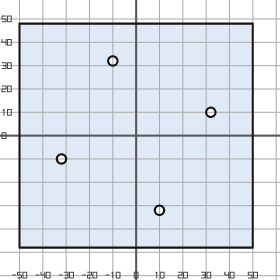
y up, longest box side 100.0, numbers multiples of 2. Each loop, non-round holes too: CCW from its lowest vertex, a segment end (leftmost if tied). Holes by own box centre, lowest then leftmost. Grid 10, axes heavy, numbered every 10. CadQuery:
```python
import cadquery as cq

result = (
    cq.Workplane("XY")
    .moveTo(-50.0, -48.0)
    .lineTo(50.0, -48.0)
    .lineTo(50.0, 48.0)
    .lineTo(-50.0, 48.0)
    .close()
    .moveTo(10.0, -32.0)
    .circle(2.0)
    .moveTo(-32.0, -10.0)
    .circle(2.0)
    .moveTo(32.0, 10.0)
    .circle(2.0)
    .moveTo(-10.0, 32.0)
    .circle(2.0)
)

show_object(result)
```